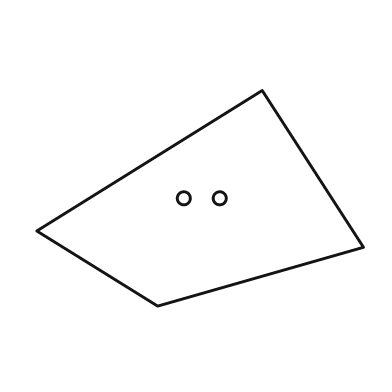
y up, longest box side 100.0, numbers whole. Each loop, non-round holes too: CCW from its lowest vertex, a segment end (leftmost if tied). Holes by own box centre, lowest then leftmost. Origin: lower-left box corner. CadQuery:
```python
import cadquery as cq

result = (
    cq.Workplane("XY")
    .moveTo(37.0, 0.0)
    .lineTo(100.0, 18.0)
    .lineTo(69.0, 66.0)
    .lineTo(0.0, 23.0)
    .close()
    .moveTo(45.0, 33.0)
    .circle(2.0)
    .moveTo(56.0, 33.0)
    .circle(2.0)
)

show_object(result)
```